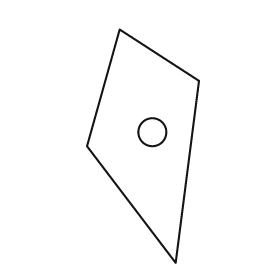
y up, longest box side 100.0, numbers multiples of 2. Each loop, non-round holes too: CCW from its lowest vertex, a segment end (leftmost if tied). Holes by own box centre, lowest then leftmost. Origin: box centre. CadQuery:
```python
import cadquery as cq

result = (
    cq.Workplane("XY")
    .moveTo(14.0, -50.0)
    .lineTo(24.0, 28.0)
    .lineTo(-10.0, 50.0)
    .lineTo(-24.0, 0.0)
    .close()
    .moveTo(4.0, 6.0)
    .circle(6.0)
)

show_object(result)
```